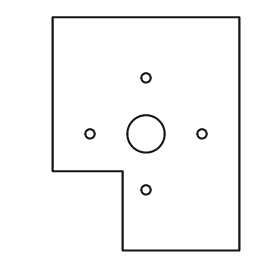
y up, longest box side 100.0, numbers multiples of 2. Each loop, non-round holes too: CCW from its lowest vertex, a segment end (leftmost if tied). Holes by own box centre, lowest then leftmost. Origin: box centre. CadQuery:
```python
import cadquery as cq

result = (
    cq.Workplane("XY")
    .moveTo(-10.0, -50.0)
    .lineTo(40.0, -50.0)
    .lineTo(40.0, 50.0)
    .lineTo(-40.0, 50.0)
    .lineTo(-40.0, -16.0)
    .lineTo(-10.0, -16.0)
    .close()
    .moveTo(0.0, -24.0)
    .circle(2.0)
    .moveTo(-24.0, 0.0)
    .circle(2.0)
    .moveTo(0.0, 0.0)
    .circle(8.0)
    .moveTo(24.0, 0.0)
    .circle(2.0)
    .moveTo(0.0, 24.0)
    .circle(2.0)
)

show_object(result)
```